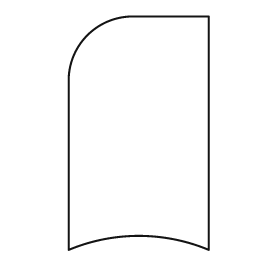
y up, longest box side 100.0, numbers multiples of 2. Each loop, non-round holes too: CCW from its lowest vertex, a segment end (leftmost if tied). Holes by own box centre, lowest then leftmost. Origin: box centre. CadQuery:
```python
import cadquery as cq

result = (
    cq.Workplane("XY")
    .moveTo(-30.0, -50.0)
    .threePointArc((0.0, -44.0), (30.0, -50.0))
    .lineTo(30.0, 50.0)
    .lineTo(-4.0, 50.0)
    .threePointArc((-22.0, 42.0), (-30.0, 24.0))
    .close()
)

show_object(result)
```